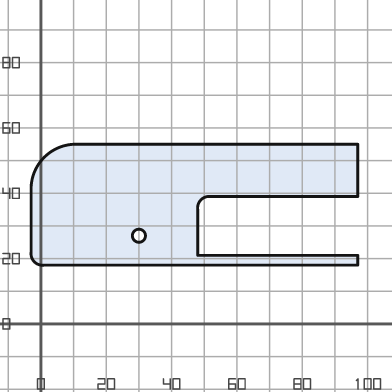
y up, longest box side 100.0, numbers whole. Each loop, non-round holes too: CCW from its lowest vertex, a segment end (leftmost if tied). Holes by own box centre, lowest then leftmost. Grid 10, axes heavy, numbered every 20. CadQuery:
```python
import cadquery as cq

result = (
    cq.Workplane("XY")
    .moveTo(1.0, 18.0)
    .lineTo(97.0, 18.0)
    .lineTo(97.0, 21.0)
    .lineTo(48.0, 21.0)
    .lineTo(48.0, 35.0)
    .threePointArc((49.0, 38.0), (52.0, 39.0))
    .lineTo(97.0, 39.0)
    .lineTo(97.0, 55.0)
    .lineTo(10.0, 55.0)
    .threePointArc((1.0, 51.0), (-3.0, 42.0))
    .lineTo(-3.0, 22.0)
    .threePointArc((-2.0, 19.0), (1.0, 18.0))
    .close()
    .moveTo(30.0, 27.0)
    .circle(2.0)
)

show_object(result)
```